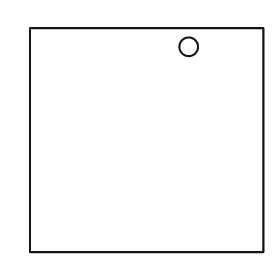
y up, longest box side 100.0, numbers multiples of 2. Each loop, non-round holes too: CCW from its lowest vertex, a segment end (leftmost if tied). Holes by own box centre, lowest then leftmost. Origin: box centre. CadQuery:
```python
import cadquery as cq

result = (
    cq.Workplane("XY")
    .moveTo(-50.0, -48.0)
    .lineTo(50.0, -48.0)
    .lineTo(50.0, 48.0)
    .lineTo(-50.0, 48.0)
    .close()
    .moveTo(18.0, 40.0)
    .circle(4.0)
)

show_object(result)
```